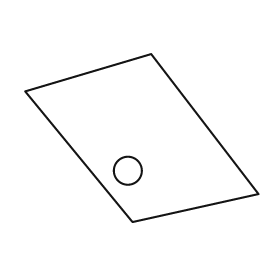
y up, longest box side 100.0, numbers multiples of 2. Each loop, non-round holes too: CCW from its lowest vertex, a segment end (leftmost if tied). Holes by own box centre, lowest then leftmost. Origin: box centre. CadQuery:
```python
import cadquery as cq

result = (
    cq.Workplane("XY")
    .moveTo(-4.0, -36.0)
    .lineTo(50.0, -24.0)
    .lineTo(4.0, 36.0)
    .lineTo(-50.0, 20.0)
    .close()
    .moveTo(-6.0, -14.0)
    .circle(6.0)
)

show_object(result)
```